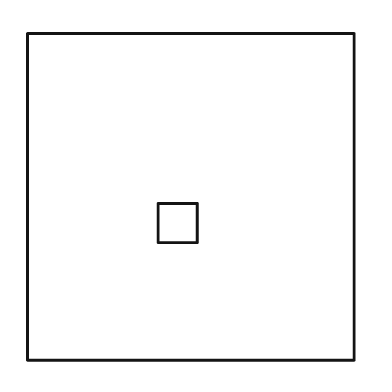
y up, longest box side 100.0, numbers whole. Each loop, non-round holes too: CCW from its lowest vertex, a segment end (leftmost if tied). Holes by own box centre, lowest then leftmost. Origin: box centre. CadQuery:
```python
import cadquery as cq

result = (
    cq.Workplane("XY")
    .moveTo(-50.0, -50.0)
    .lineTo(50.0, -50.0)
    .lineTo(50.0, 50.0)
    .lineTo(-50.0, 50.0)
    .close()
    .moveTo(-10.0, -14.0)
    .lineTo(2.0, -14.0)
    .lineTo(2.0, -2.0)
    .lineTo(-10.0, -2.0)
    .close()
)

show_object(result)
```